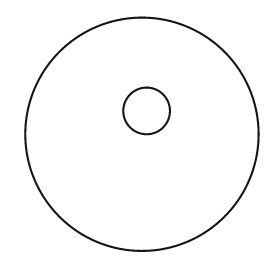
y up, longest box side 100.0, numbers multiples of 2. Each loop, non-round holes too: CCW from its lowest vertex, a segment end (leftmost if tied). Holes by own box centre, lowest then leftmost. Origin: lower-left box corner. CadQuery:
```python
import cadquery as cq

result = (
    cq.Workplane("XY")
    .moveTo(50.0, 50.0)
    .circle(50.0)
    .moveTo(52.0, 60.0)
    .circle(10.0)
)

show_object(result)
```